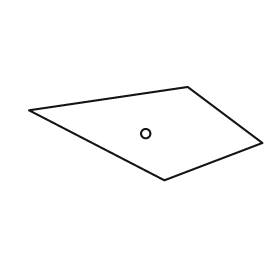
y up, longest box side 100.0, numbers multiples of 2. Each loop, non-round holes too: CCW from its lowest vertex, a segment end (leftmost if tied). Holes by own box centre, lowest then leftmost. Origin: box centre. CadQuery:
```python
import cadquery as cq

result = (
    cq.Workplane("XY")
    .moveTo(8.0, -20.0)
    .lineTo(50.0, -4.0)
    .lineTo(18.0, 20.0)
    .lineTo(-50.0, 10.0)
    .close()
    .moveTo(0.0, 0.0)
    .circle(2.0)
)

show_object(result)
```